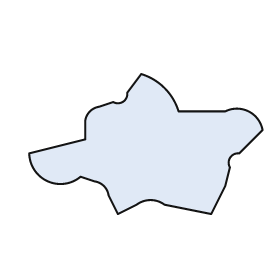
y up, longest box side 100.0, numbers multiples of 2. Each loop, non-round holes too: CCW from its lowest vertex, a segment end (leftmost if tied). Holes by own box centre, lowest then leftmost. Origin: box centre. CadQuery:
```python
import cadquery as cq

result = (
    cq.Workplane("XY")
    .moveTo(-12.0, -30.0)
    .lineTo(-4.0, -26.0)
    .threePointArc((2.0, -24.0), (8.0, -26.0))
    .lineTo(28.0, -30.0)
    .lineTo(34.0, -18.0)
    .lineTo(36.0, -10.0)
    .threePointArc((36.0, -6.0), (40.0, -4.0))
    .lineTo(50.0, 6.0)
    .threePointArc((44.0, 14.0), (34.0, 14.0))
    .lineTo(14.0, 14.0)
    .threePointArc((8.0, 24.0), (-2.0, 30.0))
    .lineTo(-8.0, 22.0)
    .threePointArc((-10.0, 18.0), (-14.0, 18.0))
    .lineTo(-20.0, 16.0)
    .threePointArc((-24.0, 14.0), (-26.0, 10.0))
    .lineTo(-26.0, 2.0)
    .lineTo(-50.0, -4.0)
    .threePointArc((-42.0, -16.0), (-28.0, -14.0))
    .lineTo(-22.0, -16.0)
    .threePointArc((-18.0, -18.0), (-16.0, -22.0))
    .close()
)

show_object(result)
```